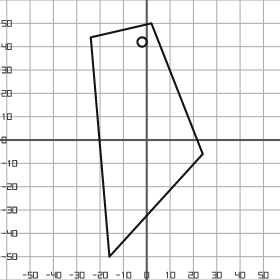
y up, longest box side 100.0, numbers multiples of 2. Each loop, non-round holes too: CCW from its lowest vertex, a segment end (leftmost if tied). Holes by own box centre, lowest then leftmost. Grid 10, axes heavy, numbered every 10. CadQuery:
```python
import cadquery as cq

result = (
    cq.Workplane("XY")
    .moveTo(-16.0, -50.0)
    .lineTo(24.0, -6.0)
    .lineTo(2.0, 50.0)
    .lineTo(-24.0, 44.0)
    .close()
    .moveTo(-2.0, 42.0)
    .circle(2.0)
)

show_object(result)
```